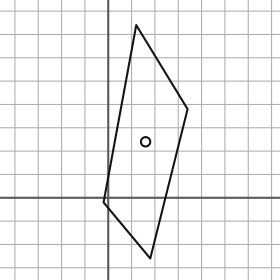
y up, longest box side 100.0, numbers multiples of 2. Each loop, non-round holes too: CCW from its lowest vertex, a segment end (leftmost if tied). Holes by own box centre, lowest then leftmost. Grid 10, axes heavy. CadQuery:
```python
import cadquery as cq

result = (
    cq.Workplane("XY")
    .moveTo(18.0, -26.0)
    .lineTo(34.0, 38.0)
    .lineTo(12.0, 74.0)
    .lineTo(-2.0, -2.0)
    .close()
    .moveTo(16.0, 24.0)
    .circle(2.0)
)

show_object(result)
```